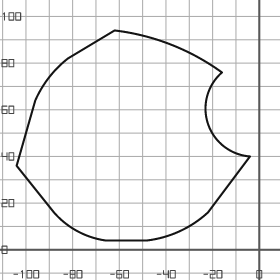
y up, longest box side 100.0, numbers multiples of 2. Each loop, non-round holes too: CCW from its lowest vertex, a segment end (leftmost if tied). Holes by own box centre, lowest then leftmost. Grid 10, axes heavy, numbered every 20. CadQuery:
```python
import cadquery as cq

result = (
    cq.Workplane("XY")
    .moveTo(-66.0, 4.0)
    .lineTo(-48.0, 4.0)
    .threePointArc((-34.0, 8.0), (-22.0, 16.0))
    .lineTo(-4.0, 40.0)
    .threePointArc((-22.0, 54.0), (-16.0, 76.0))
    .threePointArc((-38.0, 88.0), (-62.0, 94.0))
    .lineTo(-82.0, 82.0)
    .threePointArc((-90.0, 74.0), (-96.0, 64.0))
    .lineTo(-104.0, 36.0)
    .lineTo(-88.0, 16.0)
    .threePointArc((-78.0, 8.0), (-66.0, 4.0))
    .close()
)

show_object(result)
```